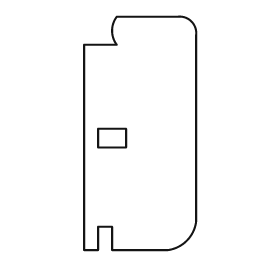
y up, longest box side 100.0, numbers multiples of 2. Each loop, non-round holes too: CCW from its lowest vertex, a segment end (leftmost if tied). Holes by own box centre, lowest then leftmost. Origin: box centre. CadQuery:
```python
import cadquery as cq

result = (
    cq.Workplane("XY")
    .moveTo(-24.0, -50.0)
    .lineTo(-18.0, -50.0)
    .lineTo(-18.0, -40.0)
    .lineTo(-12.0, -40.0)
    .lineTo(-12.0, -50.0)
    .lineTo(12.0, -50.0)
    .threePointArc((20.0, -46.0), (24.0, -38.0))
    .lineTo(24.0, 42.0)
    .threePointArc((22.0, 48.0), (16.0, 50.0))
    .lineTo(-10.0, 50.0)
    .threePointArc((-12.0, 44.0), (-10.0, 38.0))
    .lineTo(-24.0, 38.0)
    .close()
    .moveTo(-18.0, -6.0)
    .lineTo(-6.0, -6.0)
    .lineTo(-6.0, 2.0)
    .lineTo(-18.0, 2.0)
    .close()
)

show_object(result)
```